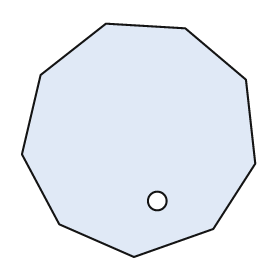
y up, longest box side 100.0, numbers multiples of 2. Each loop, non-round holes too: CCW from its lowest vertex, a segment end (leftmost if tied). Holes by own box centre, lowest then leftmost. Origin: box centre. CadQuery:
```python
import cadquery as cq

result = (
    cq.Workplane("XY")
    .moveTo(-2.0, -50.0)
    .lineTo(32.0, -38.0)
    .lineTo(50.0, -10.0)
    .lineTo(46.0, 26.0)
    .lineTo(20.0, 48.0)
    .lineTo(-14.0, 50.0)
    .lineTo(-42.0, 28.0)
    .lineTo(-50.0, -6.0)
    .lineTo(-34.0, -36.0)
    .close()
    .moveTo(8.0, -26.0)
    .circle(4.0)
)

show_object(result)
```